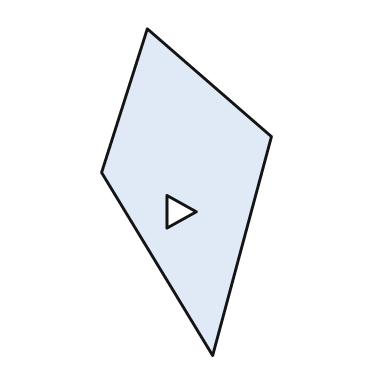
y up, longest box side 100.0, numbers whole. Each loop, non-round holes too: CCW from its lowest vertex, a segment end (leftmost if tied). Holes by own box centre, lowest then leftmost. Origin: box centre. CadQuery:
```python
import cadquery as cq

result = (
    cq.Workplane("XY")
    .moveTo(8.0, -50.0)
    .lineTo(26.0, 17.0)
    .lineTo(-12.0, 50.0)
    .lineTo(-26.0, 6.0)
    .close()
    .moveTo(-6.0, -11.0)
    .lineTo(3.0, -6.0)
    .lineTo(-6.0, -1.0)
    .close()
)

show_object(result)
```